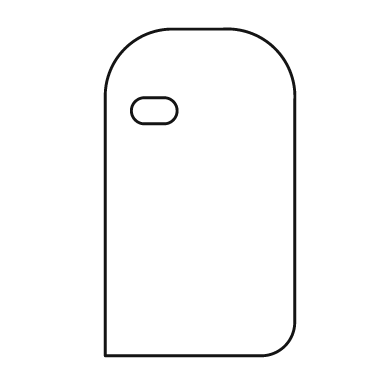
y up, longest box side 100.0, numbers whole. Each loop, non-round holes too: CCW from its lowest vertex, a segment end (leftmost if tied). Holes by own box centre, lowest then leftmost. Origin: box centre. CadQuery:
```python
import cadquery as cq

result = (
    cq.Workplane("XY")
    .moveTo(-29.0, -50.0)
    .lineTo(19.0, -50.0)
    .threePointArc((26.0, -47.0), (29.0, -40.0))
    .lineTo(29.0, 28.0)
    .threePointArc((23.0, 44.0), (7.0, 50.0))
    .lineTo(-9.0, 50.0)
    .threePointArc((-23.0, 44.0), (-29.0, 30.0))
    .close()
    .moveTo(-17.0, 21.0)
    .lineTo(-11.0, 21.0)
    .threePointArc((-7.0, 25.0), (-11.0, 29.0))
    .lineTo(-17.0, 29.0)
    .threePointArc((-21.0, 25.0), (-17.0, 21.0))
    .close()
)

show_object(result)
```